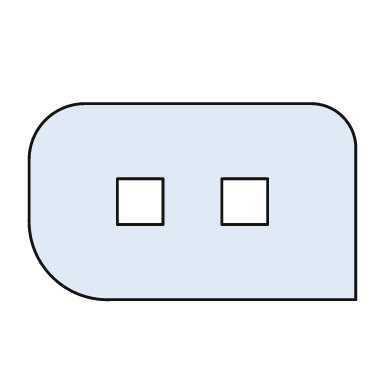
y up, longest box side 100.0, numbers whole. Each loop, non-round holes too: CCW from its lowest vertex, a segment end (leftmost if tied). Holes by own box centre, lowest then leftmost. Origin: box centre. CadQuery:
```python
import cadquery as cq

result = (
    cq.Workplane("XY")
    .moveTo(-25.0, -30.0)
    .lineTo(50.0, -30.0)
    .lineTo(50.0, 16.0)
    .threePointArc((46.0, 26.0), (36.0, 30.0))
    .lineTo(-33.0, 30.0)
    .threePointArc((-45.0, 25.0), (-50.0, 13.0))
    .lineTo(-50.0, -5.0)
    .threePointArc((-43.0, -23.0), (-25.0, -30.0))
    .close()
    .moveTo(-23.0, -7.0)
    .lineTo(-9.0, -7.0)
    .lineTo(-9.0, 7.0)
    .lineTo(-23.0, 7.0)
    .close()
    .moveTo(9.0, -7.0)
    .lineTo(23.0, -7.0)
    .lineTo(23.0, 7.0)
    .lineTo(9.0, 7.0)
    .close()
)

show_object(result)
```